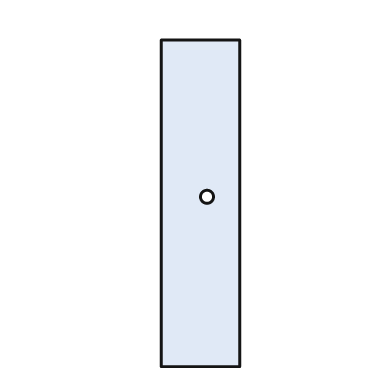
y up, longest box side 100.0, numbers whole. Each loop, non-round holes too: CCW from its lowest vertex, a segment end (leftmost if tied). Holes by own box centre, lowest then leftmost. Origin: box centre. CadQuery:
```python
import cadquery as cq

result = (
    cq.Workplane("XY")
    .moveTo(-12.0, -50.0)
    .lineTo(12.0, -50.0)
    .lineTo(12.0, 50.0)
    .lineTo(-12.0, 50.0)
    .close()
    .moveTo(2.0, 2.0)
    .circle(2.0)
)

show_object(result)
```